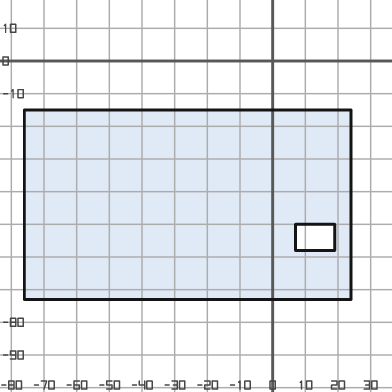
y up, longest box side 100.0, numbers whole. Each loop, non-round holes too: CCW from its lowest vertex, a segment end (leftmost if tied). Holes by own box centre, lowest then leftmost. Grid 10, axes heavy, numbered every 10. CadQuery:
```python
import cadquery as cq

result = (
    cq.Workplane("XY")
    .moveTo(-76.0, -73.0)
    .lineTo(24.0, -73.0)
    .lineTo(24.0, -15.0)
    .lineTo(-76.0, -15.0)
    .close()
    .moveTo(7.0, -58.0)
    .lineTo(19.0, -58.0)
    .lineTo(19.0, -50.0)
    .lineTo(7.0, -50.0)
    .close()
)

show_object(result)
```